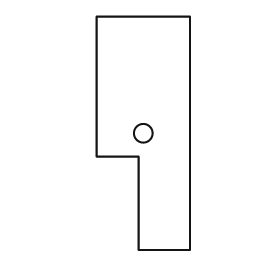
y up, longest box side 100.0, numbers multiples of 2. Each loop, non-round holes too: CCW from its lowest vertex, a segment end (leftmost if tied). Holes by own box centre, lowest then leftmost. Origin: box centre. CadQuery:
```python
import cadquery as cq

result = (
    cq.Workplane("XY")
    .moveTo(-2.0, -50.0)
    .lineTo(20.0, -50.0)
    .lineTo(20.0, 50.0)
    .lineTo(-20.0, 50.0)
    .lineTo(-20.0, -10.0)
    .lineTo(-2.0, -10.0)
    .close()
    .moveTo(0.0, 0.0)
    .circle(4.0)
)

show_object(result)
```